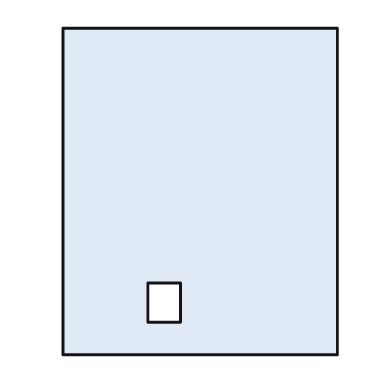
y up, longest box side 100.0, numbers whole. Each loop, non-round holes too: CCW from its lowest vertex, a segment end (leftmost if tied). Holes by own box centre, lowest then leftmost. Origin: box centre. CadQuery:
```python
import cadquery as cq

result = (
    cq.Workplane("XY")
    .moveTo(-42.0, -50.0)
    .lineTo(42.0, -50.0)
    .lineTo(42.0, 50.0)
    .lineTo(-42.0, 50.0)
    .close()
    .moveTo(-16.0, -40.0)
    .lineTo(-6.0, -40.0)
    .lineTo(-6.0, -28.0)
    .lineTo(-16.0, -28.0)
    .close()
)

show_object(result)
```